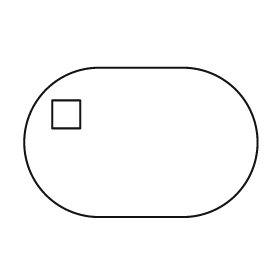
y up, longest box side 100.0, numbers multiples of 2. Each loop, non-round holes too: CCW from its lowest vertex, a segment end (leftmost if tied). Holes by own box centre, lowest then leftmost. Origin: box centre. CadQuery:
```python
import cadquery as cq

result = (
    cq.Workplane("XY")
    .moveTo(-18.0, -32.0)
    .lineTo(18.0, -32.0)
    .threePointArc((50.0, 0.0), (18.0, 32.0))
    .lineTo(-18.0, 32.0)
    .threePointArc((-50.0, 0.0), (-18.0, -32.0))
    .close()
    .moveTo(-38.0, 6.0)
    .lineTo(-26.0, 6.0)
    .lineTo(-26.0, 18.0)
    .lineTo(-38.0, 18.0)
    .close()
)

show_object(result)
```